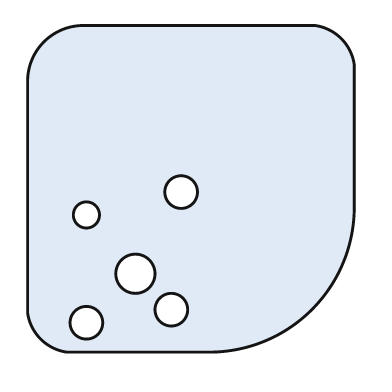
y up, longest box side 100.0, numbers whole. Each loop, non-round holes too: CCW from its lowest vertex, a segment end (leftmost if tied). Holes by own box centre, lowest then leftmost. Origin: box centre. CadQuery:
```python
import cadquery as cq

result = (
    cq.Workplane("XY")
    .moveTo(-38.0, -50.0)
    .lineTo(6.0, -50.0)
    .threePointArc((37.0, -37.0), (50.0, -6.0))
    .lineTo(50.0, 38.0)
    .threePointArc((46.0, 46.0), (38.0, 50.0))
    .lineTo(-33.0, 50.0)
    .threePointArc((-45.0, 45.0), (-50.0, 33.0))
    .lineTo(-50.0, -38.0)
    .threePointArc((-46.0, -46.0), (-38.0, -50.0))
    .close()
    .moveTo(-32.0, -41.0)
    .circle(5.0)
    .moveTo(-6.0, -37.0)
    .circle(5.0)
    .moveTo(-17.0, -26.0)
    .circle(6.0)
    .moveTo(-32.0, -8.0)
    .circle(4.0)
    .moveTo(-3.0, -1.0)
    .circle(5.0)
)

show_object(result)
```